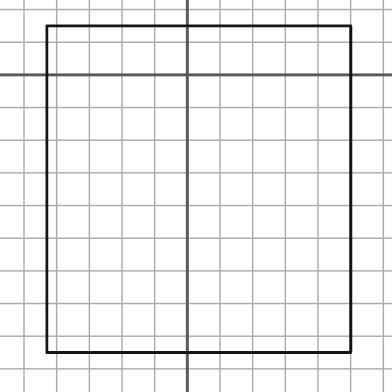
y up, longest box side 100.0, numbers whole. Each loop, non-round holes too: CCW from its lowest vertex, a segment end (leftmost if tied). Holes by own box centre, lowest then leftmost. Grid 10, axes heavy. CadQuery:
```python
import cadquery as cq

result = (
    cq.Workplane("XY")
    .moveTo(-43.0, -85.0)
    .lineTo(50.0, -85.0)
    .lineTo(50.0, 15.0)
    .lineTo(-43.0, 15.0)
    .close()
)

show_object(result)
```